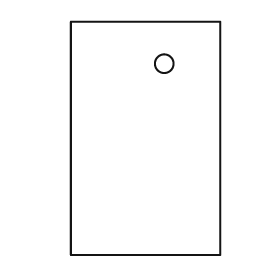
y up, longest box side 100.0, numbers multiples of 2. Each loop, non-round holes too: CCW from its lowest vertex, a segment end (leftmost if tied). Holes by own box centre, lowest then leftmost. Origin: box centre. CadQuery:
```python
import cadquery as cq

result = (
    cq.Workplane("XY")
    .moveTo(-32.0, -50.0)
    .lineTo(32.0, -50.0)
    .lineTo(32.0, 50.0)
    .lineTo(-32.0, 50.0)
    .close()
    .moveTo(8.0, 32.0)
    .circle(4.0)
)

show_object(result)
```